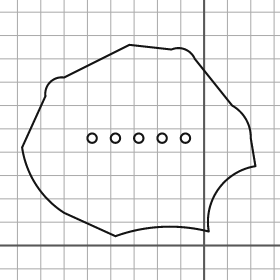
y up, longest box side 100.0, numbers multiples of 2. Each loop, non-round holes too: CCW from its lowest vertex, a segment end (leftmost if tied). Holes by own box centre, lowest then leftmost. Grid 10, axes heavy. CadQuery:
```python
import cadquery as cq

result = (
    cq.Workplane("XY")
    .moveTo(-38.0, 4.0)
    .threePointArc((-18.0, 8.0), (2.0, 6.0))
    .threePointArc((6.0, 24.0), (22.0, 34.0))
    .lineTo(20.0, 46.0)
    .threePointArc((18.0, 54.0), (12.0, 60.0))
    .lineTo(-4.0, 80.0)
    .threePointArc((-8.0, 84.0), (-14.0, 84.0))
    .lineTo(-32.0, 86.0)
    .lineTo(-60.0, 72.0)
    .threePointArc((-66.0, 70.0), (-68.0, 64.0))
    .lineTo(-78.0, 42.0)
    .threePointArc((-72.0, 26.0), (-60.0, 14.0))
    .close()
    .moveTo(-48.0, 46.0)
    .circle(2.0)
    .moveTo(-38.0, 46.0)
    .circle(2.0)
    .moveTo(-28.0, 46.0)
    .circle(2.0)
    .moveTo(-18.0, 46.0)
    .circle(2.0)
    .moveTo(-8.0, 46.0)
    .circle(2.0)
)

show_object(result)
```